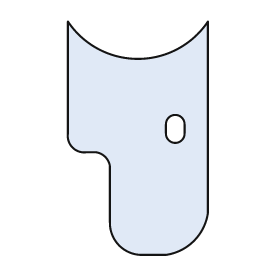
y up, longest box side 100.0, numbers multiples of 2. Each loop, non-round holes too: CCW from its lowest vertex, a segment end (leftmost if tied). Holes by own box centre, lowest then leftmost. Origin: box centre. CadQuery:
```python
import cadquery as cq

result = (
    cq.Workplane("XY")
    .moveTo(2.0, -50.0)
    .lineTo(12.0, -50.0)
    .threePointArc((24.0, -44.0), (30.0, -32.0))
    .lineTo(30.0, 50.0)
    .threePointArc((0.0, 34.0), (-30.0, 50.0))
    .lineTo(-30.0, 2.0)
    .threePointArc((-28.0, -4.0), (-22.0, -6.0))
    .lineTo(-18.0, -6.0)
    .threePointArc((-14.0, -8.0), (-12.0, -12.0))
    .lineTo(-12.0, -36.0)
    .threePointArc((-8.0, -46.0), (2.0, -50.0))
    .close()
    .moveTo(12.0, 2.0)
    .threePointArc((16.0, -2.0), (20.0, 2.0))
    .lineTo(20.0, 6.0)
    .threePointArc((16.0, 10.0), (12.0, 6.0))
    .close()
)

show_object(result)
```